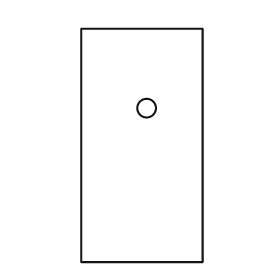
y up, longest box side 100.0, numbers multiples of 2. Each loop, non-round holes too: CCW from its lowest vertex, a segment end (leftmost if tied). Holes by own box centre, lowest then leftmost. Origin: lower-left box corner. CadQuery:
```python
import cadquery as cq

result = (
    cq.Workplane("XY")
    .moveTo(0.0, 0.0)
    .lineTo(52.0, 0.0)
    .lineTo(52.0, 100.0)
    .lineTo(0.0, 100.0)
    .close()
    .moveTo(28.0, 66.0)
    .circle(4.0)
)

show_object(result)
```